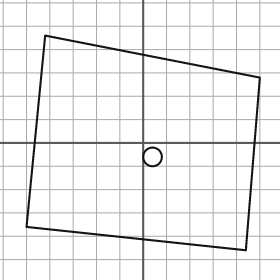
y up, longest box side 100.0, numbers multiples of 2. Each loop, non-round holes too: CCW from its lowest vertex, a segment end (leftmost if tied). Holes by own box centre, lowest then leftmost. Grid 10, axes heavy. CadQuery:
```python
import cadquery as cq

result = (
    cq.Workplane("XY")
    .moveTo(44.0, -46.0)
    .lineTo(50.0, 28.0)
    .lineTo(-42.0, 46.0)
    .lineTo(-50.0, -36.0)
    .close()
    .moveTo(4.0, -6.0)
    .circle(4.0)
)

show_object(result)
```